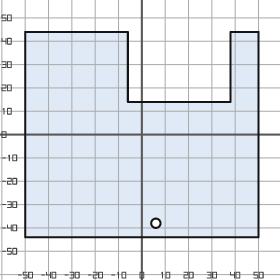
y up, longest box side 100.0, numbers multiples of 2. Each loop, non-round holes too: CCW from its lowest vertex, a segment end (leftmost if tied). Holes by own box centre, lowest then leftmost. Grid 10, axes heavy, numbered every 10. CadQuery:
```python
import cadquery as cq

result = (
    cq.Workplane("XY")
    .moveTo(-50.0, -44.0)
    .lineTo(50.0, -44.0)
    .lineTo(50.0, 44.0)
    .lineTo(38.0, 44.0)
    .lineTo(38.0, 14.0)
    .lineTo(-6.0, 14.0)
    .lineTo(-6.0, 44.0)
    .lineTo(-50.0, 44.0)
    .close()
    .moveTo(6.0, -38.0)
    .circle(2.0)
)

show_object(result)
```